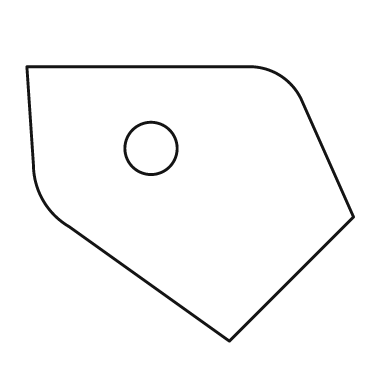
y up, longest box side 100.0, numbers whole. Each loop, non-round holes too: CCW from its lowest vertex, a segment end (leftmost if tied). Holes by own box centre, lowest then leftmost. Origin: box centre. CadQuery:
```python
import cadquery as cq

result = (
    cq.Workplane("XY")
    .moveTo(12.0, -42.0)
    .lineTo(50.0, -4.0)
    .lineTo(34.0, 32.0)
    .threePointArc((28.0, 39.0), (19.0, 42.0))
    .lineTo(-50.0, 42.0)
    .lineTo(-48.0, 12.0)
    .threePointArc((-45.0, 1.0), (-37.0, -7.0))
    .close()
    .moveTo(-12.0, 17.0)
    .circle(8.0)
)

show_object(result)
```